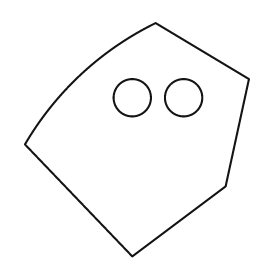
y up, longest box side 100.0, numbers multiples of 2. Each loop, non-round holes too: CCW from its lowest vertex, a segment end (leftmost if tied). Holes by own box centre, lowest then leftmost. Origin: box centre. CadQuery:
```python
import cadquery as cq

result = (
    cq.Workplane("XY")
    .moveTo(-2.0, -50.0)
    .lineTo(38.0, -20.0)
    .lineTo(48.0, 26.0)
    .lineTo(8.0, 50.0)
    .threePointArc((-24.0, 28.0), (-48.0, -2.0))
    .close()
    .moveTo(-2.0, 18.0)
    .circle(8.0)
    .moveTo(20.0, 18.0)
    .circle(8.0)
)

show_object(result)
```